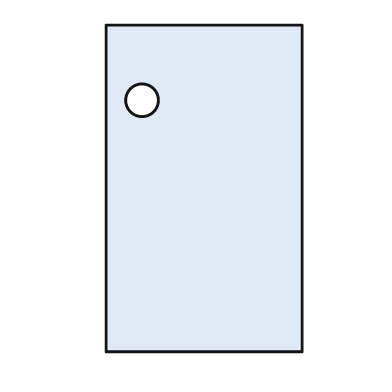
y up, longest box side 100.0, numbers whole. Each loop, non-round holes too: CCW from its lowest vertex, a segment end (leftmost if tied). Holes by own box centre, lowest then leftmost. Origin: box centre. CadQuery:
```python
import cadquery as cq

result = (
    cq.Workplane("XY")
    .moveTo(-30.0, -50.0)
    .lineTo(30.0, -50.0)
    .lineTo(30.0, 50.0)
    .lineTo(-30.0, 50.0)
    .close()
    .moveTo(-19.0, 27.0)
    .circle(5.0)
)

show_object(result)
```